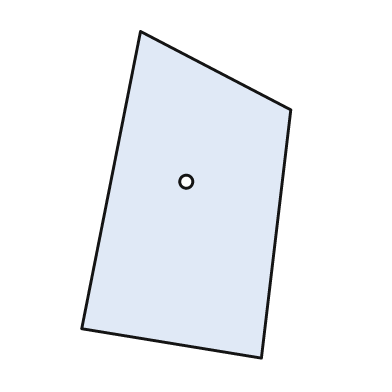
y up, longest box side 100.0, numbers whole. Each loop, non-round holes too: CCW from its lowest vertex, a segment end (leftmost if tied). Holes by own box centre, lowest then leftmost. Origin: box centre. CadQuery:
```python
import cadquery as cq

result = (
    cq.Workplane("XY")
    .moveTo(23.0, -50.0)
    .lineTo(32.0, 26.0)
    .lineTo(-14.0, 50.0)
    .lineTo(-32.0, -41.0)
    .close()
    .moveTo(0.0, 4.0)
    .circle(2.0)
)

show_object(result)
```